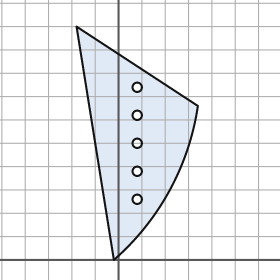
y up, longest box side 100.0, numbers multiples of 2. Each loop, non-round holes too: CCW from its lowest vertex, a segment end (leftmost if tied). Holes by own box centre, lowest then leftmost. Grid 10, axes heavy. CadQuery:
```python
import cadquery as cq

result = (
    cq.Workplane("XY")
    .moveTo(-2.0, 0.0)
    .threePointArc((22.0, 30.0), (34.0, 66.0))
    .lineTo(-18.0, 100.0)
    .close()
    .moveTo(8.0, 26.0)
    .circle(2.0)
    .moveTo(8.0, 38.0)
    .circle(2.0)
    .moveTo(8.0, 50.0)
    .circle(2.0)
    .moveTo(8.0, 62.0)
    .circle(2.0)
    .moveTo(8.0, 74.0)
    .circle(2.0)
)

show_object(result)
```